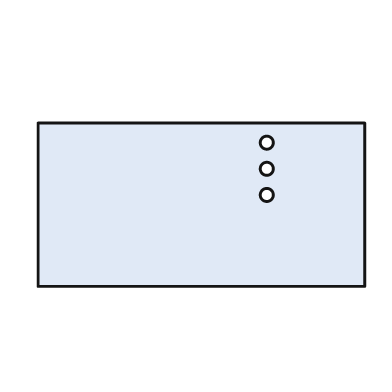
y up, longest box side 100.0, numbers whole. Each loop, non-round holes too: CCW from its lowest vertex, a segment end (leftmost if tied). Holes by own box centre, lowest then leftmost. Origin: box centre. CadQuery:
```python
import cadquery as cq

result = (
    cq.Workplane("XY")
    .moveTo(-50.0, -25.0)
    .lineTo(50.0, -25.0)
    .lineTo(50.0, 25.0)
    .lineTo(-50.0, 25.0)
    .close()
    .moveTo(20.0, 3.0)
    .circle(2.0)
    .moveTo(20.0, 11.0)
    .circle(2.0)
    .moveTo(20.0, 19.0)
    .circle(2.0)
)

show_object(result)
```